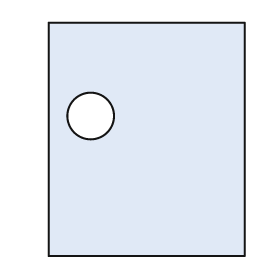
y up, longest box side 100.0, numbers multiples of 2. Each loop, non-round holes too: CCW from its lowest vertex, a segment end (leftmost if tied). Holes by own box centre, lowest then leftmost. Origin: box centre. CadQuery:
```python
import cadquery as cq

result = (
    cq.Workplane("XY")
    .moveTo(-42.0, -50.0)
    .lineTo(42.0, -50.0)
    .lineTo(42.0, 50.0)
    .lineTo(-42.0, 50.0)
    .close()
    .moveTo(-24.0, 10.0)
    .circle(10.0)
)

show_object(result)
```